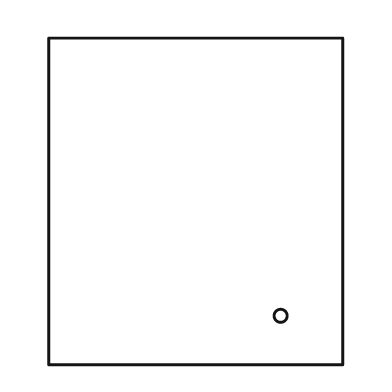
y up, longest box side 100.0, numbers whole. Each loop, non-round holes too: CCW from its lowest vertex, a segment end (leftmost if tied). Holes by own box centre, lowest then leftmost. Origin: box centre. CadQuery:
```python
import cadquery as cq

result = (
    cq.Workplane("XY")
    .moveTo(-45.0, -50.0)
    .lineTo(45.0, -50.0)
    .lineTo(45.0, 50.0)
    .lineTo(-45.0, 50.0)
    .close()
    .moveTo(26.0, -35.0)
    .circle(2.0)
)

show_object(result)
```